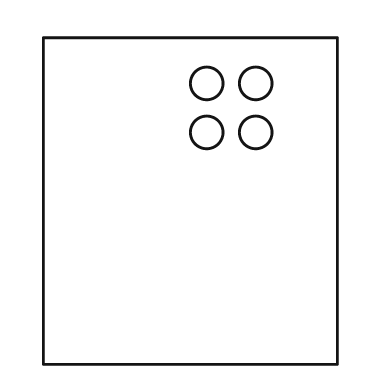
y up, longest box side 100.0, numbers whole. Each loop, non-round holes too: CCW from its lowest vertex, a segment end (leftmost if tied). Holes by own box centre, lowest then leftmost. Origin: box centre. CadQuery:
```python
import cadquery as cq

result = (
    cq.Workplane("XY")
    .moveTo(-45.0, -50.0)
    .lineTo(45.0, -50.0)
    .lineTo(45.0, 50.0)
    .lineTo(-45.0, 50.0)
    .close()
    .moveTo(5.0, 21.0)
    .circle(5.0)
    .moveTo(20.0, 21.0)
    .circle(5.0)
    .moveTo(5.0, 36.0)
    .circle(5.0)
    .moveTo(20.0, 36.0)
    .circle(5.0)
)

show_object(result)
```